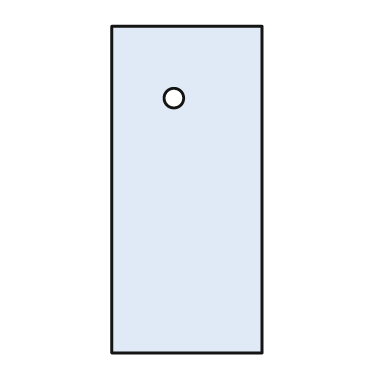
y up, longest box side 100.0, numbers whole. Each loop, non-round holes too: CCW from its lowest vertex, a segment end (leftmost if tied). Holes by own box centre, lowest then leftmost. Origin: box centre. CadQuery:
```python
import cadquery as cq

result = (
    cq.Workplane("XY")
    .moveTo(-23.0, -50.0)
    .lineTo(23.0, -50.0)
    .lineTo(23.0, 50.0)
    .lineTo(-23.0, 50.0)
    .close()
    .moveTo(-4.0, 28.0)
    .circle(3.0)
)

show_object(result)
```